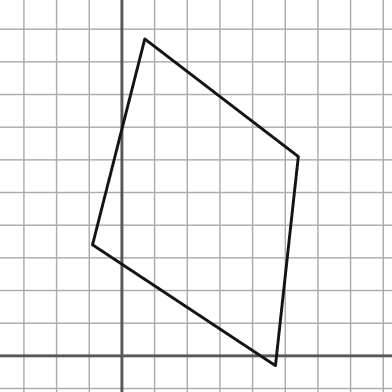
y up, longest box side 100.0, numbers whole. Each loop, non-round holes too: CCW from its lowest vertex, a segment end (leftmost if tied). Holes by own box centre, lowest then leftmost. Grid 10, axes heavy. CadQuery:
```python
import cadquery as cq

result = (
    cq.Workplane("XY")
    .moveTo(47.0, -3.0)
    .lineTo(54.0, 61.0)
    .lineTo(7.0, 97.0)
    .lineTo(-9.0, 34.0)
    .close()
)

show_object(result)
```